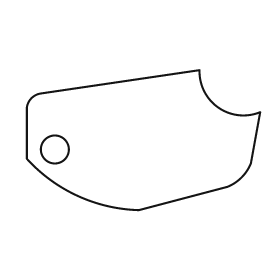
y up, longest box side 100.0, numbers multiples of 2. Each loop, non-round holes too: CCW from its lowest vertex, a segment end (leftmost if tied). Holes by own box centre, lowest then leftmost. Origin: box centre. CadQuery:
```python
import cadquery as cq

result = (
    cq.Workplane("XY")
    .moveTo(-2.0, -30.0)
    .lineTo(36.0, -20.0)
    .threePointArc((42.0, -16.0), (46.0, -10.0))
    .lineTo(50.0, 12.0)
    .threePointArc((32.0, 14.0), (24.0, 30.0))
    .lineTo(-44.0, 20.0)
    .threePointArc((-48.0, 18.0), (-50.0, 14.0))
    .lineTo(-50.0, -8.0)
    .threePointArc((-28.0, -24.0), (-2.0, -30.0))
    .close()
    .moveTo(-38.0, -4.0)
    .circle(6.0)
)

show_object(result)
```